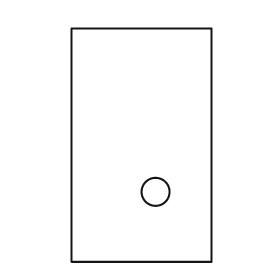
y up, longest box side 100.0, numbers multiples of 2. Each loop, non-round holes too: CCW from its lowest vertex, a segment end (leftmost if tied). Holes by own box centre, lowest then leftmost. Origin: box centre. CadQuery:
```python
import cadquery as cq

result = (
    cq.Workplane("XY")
    .moveTo(-30.0, -50.0)
    .lineTo(30.0, -50.0)
    .lineTo(30.0, 50.0)
    .lineTo(-30.0, 50.0)
    .close()
    .moveTo(6.0, -20.0)
    .circle(6.0)
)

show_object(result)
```